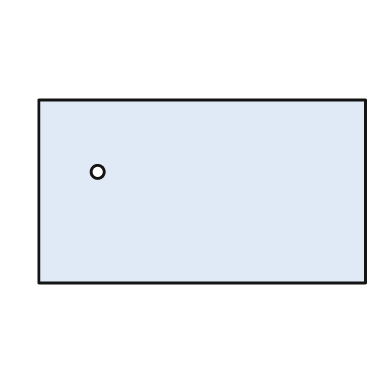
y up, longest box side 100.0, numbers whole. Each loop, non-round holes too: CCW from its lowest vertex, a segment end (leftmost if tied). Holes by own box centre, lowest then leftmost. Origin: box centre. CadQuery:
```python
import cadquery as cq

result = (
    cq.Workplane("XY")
    .moveTo(-50.0, -28.0)
    .lineTo(50.0, -28.0)
    .lineTo(50.0, 28.0)
    .lineTo(-50.0, 28.0)
    .close()
    .moveTo(-32.0, 6.0)
    .circle(2.0)
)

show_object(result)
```